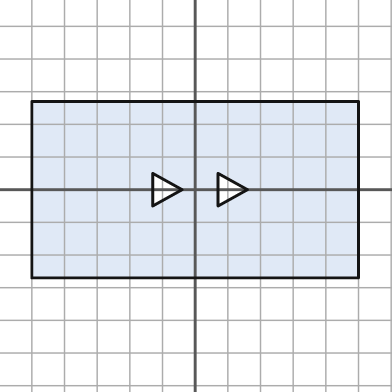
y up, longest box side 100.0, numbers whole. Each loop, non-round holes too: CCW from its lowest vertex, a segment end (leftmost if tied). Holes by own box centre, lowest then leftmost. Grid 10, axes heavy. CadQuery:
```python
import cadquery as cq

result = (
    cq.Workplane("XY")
    .moveTo(-50.0, -27.0)
    .lineTo(50.0, -27.0)
    .lineTo(50.0, 27.0)
    .lineTo(-50.0, 27.0)
    .close()
    .moveTo(-13.0, -5.0)
    .lineTo(-4.0, 0.0)
    .lineTo(-13.0, 5.0)
    .close()
    .moveTo(7.0, -5.0)
    .lineTo(16.0, 0.0)
    .lineTo(7.0, 5.0)
    .close()
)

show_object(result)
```